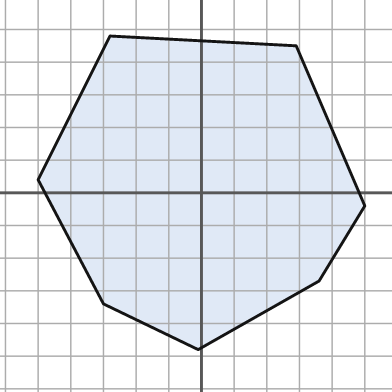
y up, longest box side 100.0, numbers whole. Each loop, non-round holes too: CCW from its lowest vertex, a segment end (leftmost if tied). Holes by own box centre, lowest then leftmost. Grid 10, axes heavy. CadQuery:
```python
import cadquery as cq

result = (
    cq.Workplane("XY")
    .moveTo(-1.0, -48.0)
    .lineTo(36.0, -27.0)
    .lineTo(50.0, -4.0)
    .lineTo(29.0, 45.0)
    .lineTo(-28.0, 48.0)
    .lineTo(-50.0, 4.0)
    .lineTo(-30.0, -34.0)
    .close()
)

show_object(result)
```